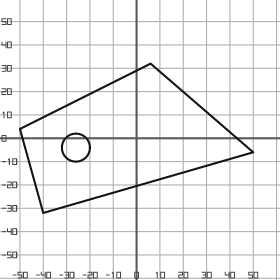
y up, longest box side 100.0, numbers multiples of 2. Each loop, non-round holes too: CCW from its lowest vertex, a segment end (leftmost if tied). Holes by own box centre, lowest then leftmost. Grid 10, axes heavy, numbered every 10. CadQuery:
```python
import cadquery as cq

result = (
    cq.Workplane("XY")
    .moveTo(-40.0, -32.0)
    .lineTo(50.0, -6.0)
    .lineTo(6.0, 32.0)
    .lineTo(-50.0, 4.0)
    .close()
    .moveTo(-26.0, -4.0)
    .circle(6.0)
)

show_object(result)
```